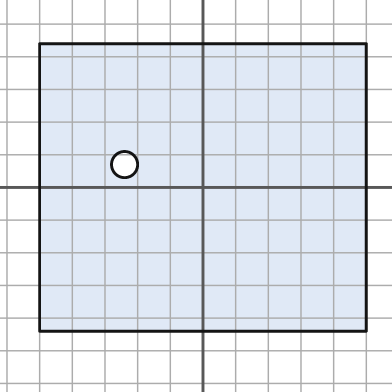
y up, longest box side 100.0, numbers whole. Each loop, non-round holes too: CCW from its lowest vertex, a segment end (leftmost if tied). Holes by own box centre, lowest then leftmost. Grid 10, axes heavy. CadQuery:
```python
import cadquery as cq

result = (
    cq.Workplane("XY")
    .moveTo(-50.0, -44.0)
    .lineTo(50.0, -44.0)
    .lineTo(50.0, 44.0)
    .lineTo(-50.0, 44.0)
    .close()
    .moveTo(-24.0, 7.0)
    .circle(4.0)
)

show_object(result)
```